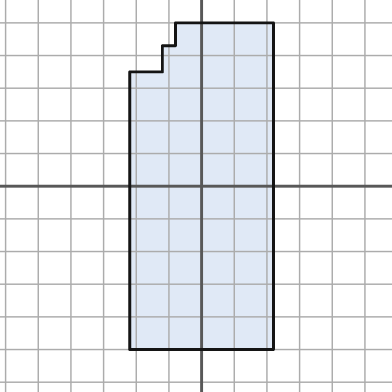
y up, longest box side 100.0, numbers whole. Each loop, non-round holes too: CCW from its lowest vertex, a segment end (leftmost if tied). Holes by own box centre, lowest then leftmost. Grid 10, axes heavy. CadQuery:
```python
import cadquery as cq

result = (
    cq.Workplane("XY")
    .moveTo(-22.0, -50.0)
    .lineTo(22.0, -50.0)
    .lineTo(22.0, 50.0)
    .lineTo(-8.0, 50.0)
    .lineTo(-8.0, 43.0)
    .lineTo(-12.0, 43.0)
    .lineTo(-12.0, 35.0)
    .lineTo(-22.0, 35.0)
    .close()
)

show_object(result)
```